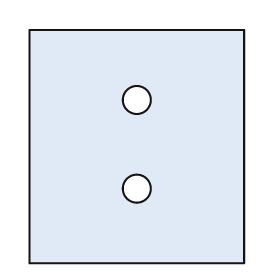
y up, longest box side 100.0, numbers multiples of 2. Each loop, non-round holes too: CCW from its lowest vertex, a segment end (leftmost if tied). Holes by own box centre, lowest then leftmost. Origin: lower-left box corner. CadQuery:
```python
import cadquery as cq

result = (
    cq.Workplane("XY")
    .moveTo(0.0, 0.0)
    .lineTo(92.0, 0.0)
    .lineTo(92.0, 100.0)
    .lineTo(0.0, 100.0)
    .close()
    .moveTo(46.0, 32.0)
    .circle(6.0)
    .moveTo(46.0, 70.0)
    .circle(6.0)
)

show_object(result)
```